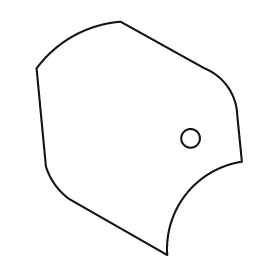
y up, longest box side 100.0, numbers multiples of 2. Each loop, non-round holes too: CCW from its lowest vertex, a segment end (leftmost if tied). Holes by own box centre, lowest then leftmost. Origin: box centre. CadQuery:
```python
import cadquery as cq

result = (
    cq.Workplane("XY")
    .moveTo(12.0, -50.0)
    .threePointArc((20.0, -24.0), (44.0, -10.0))
    .lineTo(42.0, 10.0)
    .threePointArc((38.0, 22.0), (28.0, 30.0))
    .lineTo(-8.0, 50.0)
    .threePointArc((-28.0, 44.0), (-44.0, 30.0))
    .lineTo(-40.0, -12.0)
    .threePointArc((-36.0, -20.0), (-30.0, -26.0))
    .close()
    .moveTo(22.0, 0.0)
    .circle(4.0)
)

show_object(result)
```